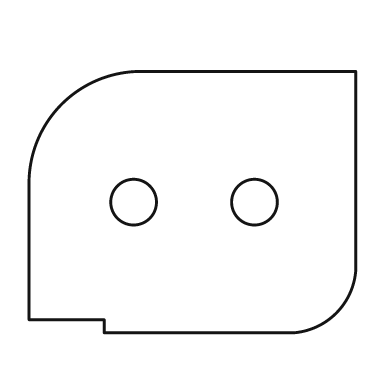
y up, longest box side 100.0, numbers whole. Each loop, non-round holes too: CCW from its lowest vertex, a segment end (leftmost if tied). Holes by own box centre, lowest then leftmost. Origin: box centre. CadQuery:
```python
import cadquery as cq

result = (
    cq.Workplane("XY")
    .moveTo(-27.0, -40.0)
    .lineTo(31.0, -40.0)
    .threePointArc((44.0, -34.0), (50.0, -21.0))
    .lineTo(50.0, 40.0)
    .lineTo(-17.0, 40.0)
    .threePointArc((-40.0, 30.0), (-50.0, 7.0))
    .lineTo(-50.0, -36.0)
    .lineTo(-27.0, -36.0)
    .close()
    .moveTo(-18.0, 0.0)
    .circle(7.0)
    .moveTo(19.0, 0.0)
    .circle(7.0)
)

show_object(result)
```